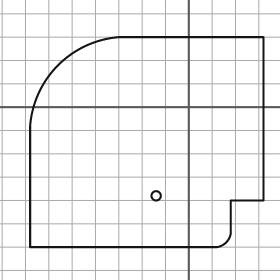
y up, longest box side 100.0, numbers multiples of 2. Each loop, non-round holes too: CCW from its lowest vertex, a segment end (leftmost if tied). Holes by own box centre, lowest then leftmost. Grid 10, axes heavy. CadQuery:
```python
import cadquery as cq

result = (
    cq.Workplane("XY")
    .moveTo(-68.0, -60.0)
    .lineTo(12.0, -60.0)
    .threePointArc((16.0, -58.0), (18.0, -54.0))
    .lineTo(18.0, -40.0)
    .lineTo(32.0, -40.0)
    .lineTo(32.0, 30.0)
    .lineTo(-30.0, 30.0)
    .threePointArc((-56.0, 18.0), (-68.0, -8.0))
    .close()
    .moveTo(-14.0, -38.0)
    .circle(2.0)
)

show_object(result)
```